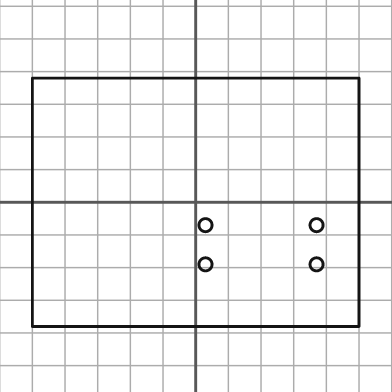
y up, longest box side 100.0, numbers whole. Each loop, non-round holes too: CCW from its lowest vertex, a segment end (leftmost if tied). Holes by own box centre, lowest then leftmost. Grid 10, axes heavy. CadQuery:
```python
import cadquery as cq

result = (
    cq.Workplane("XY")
    .moveTo(-50.0, -38.0)
    .lineTo(50.0, -38.0)
    .lineTo(50.0, 38.0)
    .lineTo(-50.0, 38.0)
    .close()
    .moveTo(3.0, -19.0)
    .circle(2.0)
    .moveTo(37.0, -19.0)
    .circle(2.0)
    .moveTo(3.0, -7.0)
    .circle(2.0)
    .moveTo(37.0, -7.0)
    .circle(2.0)
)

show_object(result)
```